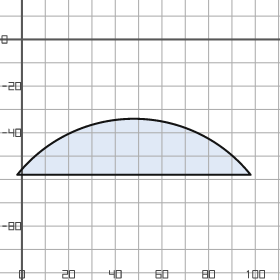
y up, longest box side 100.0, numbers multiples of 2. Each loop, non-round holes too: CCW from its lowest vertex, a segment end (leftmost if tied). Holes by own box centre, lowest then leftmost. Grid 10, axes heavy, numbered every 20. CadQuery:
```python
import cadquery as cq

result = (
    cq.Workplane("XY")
    .moveTo(-2.0, -58.0)
    .lineTo(98.0, -58.0)
    .threePointArc((48.0, -34.0), (-2.0, -58.0))
    .close()
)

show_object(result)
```